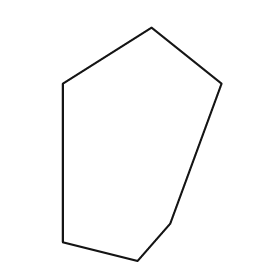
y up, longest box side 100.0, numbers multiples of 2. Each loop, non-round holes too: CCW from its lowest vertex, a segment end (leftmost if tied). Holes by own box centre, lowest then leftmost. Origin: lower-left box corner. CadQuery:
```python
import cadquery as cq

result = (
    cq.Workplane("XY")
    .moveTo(32.0, 0.0)
    .lineTo(46.0, 16.0)
    .lineTo(68.0, 76.0)
    .lineTo(38.0, 100.0)
    .lineTo(0.0, 76.0)
    .lineTo(0.0, 8.0)
    .close()
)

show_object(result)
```